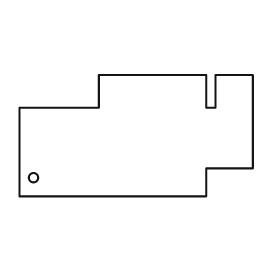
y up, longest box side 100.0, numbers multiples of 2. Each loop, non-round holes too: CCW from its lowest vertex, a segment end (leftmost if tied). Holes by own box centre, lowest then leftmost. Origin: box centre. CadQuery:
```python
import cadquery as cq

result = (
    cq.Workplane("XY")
    .moveTo(-50.0, -26.0)
    .lineTo(30.0, -26.0)
    .lineTo(30.0, -14.0)
    .lineTo(50.0, -14.0)
    .lineTo(50.0, 26.0)
    .lineTo(34.0, 26.0)
    .lineTo(34.0, 12.0)
    .lineTo(30.0, 12.0)
    .lineTo(30.0, 26.0)
    .lineTo(-16.0, 26.0)
    .lineTo(-16.0, 12.0)
    .lineTo(-50.0, 12.0)
    .close()
    .moveTo(-44.0, -18.0)
    .circle(2.0)
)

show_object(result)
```